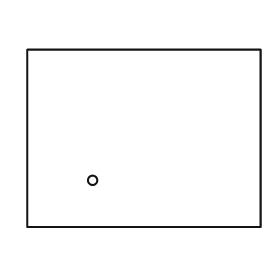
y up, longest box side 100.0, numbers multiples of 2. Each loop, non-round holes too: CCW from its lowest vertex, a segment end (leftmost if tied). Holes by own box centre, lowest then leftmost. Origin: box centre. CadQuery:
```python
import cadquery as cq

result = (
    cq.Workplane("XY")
    .moveTo(-50.0, -38.0)
    .lineTo(50.0, -38.0)
    .lineTo(50.0, 38.0)
    .lineTo(-50.0, 38.0)
    .close()
    .moveTo(-22.0, -18.0)
    .circle(2.0)
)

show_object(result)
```